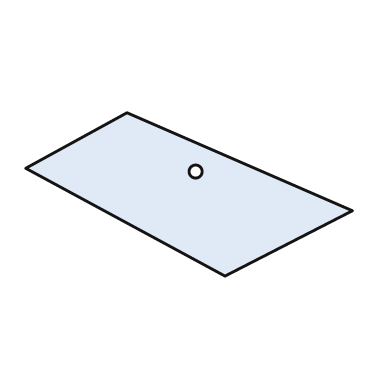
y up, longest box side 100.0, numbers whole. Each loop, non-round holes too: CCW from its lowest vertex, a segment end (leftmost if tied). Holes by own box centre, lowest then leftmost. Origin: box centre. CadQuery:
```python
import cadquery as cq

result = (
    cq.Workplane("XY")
    .moveTo(11.0, -25.0)
    .lineTo(50.0, -5.0)
    .lineTo(-19.0, 25.0)
    .lineTo(-50.0, 8.0)
    .close()
    .moveTo(2.0, 7.0)
    .circle(2.0)
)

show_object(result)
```